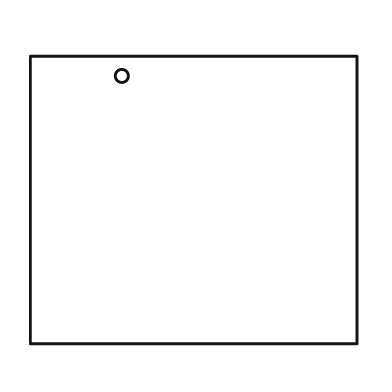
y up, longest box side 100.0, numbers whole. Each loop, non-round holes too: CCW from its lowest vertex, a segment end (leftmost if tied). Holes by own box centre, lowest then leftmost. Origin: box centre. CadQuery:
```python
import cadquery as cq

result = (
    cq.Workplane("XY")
    .moveTo(-50.0, -44.0)
    .lineTo(50.0, -44.0)
    .lineTo(50.0, 44.0)
    .lineTo(-50.0, 44.0)
    .close()
    .moveTo(-22.0, 38.0)
    .circle(2.0)
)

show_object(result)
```